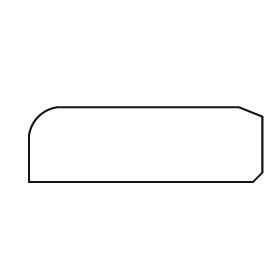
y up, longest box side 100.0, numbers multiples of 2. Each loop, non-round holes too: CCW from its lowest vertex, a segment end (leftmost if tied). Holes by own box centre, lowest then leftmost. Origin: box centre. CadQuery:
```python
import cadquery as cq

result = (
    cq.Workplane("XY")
    .moveTo(-50.0, -16.0)
    .lineTo(46.0, -16.0)
    .lineTo(50.0, -12.0)
    .lineTo(50.0, 12.0)
    .lineTo(40.0, 16.0)
    .lineTo(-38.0, 16.0)
    .threePointArc((-46.0, 12.0), (-50.0, 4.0))
    .close()
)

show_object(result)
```